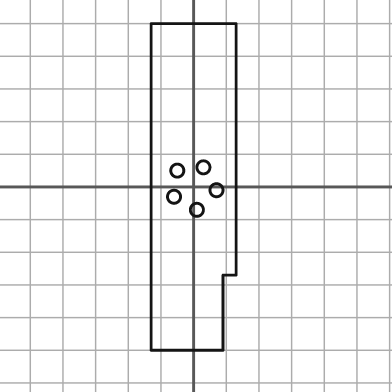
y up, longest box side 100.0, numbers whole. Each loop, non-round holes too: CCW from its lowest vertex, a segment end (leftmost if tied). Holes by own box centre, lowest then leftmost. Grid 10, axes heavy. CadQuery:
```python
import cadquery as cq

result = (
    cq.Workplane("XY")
    .moveTo(-13.0, -50.0)
    .lineTo(9.0, -50.0)
    .lineTo(9.0, -27.0)
    .lineTo(13.0, -27.0)
    .lineTo(13.0, 50.0)
    .lineTo(-13.0, 50.0)
    .close()
    .moveTo(1.0, -7.0)
    .circle(2.0)
    .moveTo(-6.0, -3.0)
    .circle(2.0)
    .moveTo(7.0, -1.0)
    .circle(2.0)
    .moveTo(-5.0, 5.0)
    .circle(2.0)
    .moveTo(3.0, 6.0)
    .circle(2.0)
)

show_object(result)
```